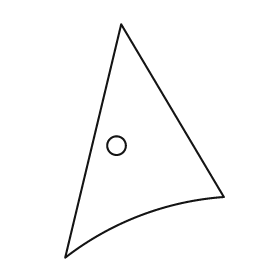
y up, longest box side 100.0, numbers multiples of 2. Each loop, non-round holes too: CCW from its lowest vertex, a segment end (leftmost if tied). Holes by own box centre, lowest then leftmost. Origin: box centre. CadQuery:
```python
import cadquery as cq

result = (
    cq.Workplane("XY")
    .moveTo(-34.0, -50.0)
    .threePointArc((-2.0, -32.0), (34.0, -24.0))
    .lineTo(-10.0, 50.0)
    .close()
    .moveTo(-12.0, -2.0)
    .circle(4.0)
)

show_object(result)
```